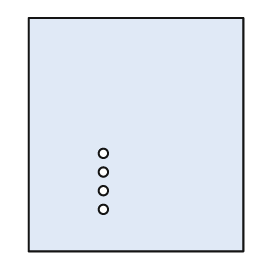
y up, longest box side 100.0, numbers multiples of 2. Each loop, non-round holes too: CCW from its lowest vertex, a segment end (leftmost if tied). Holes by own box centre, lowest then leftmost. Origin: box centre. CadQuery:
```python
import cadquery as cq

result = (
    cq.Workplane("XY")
    .moveTo(-46.0, -50.0)
    .lineTo(46.0, -50.0)
    .lineTo(46.0, 50.0)
    .lineTo(-46.0, 50.0)
    .close()
    .moveTo(-14.0, -32.0)
    .circle(2.0)
    .moveTo(-14.0, -24.0)
    .circle(2.0)
    .moveTo(-14.0, -16.0)
    .circle(2.0)
    .moveTo(-14.0, -8.0)
    .circle(2.0)
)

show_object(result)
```